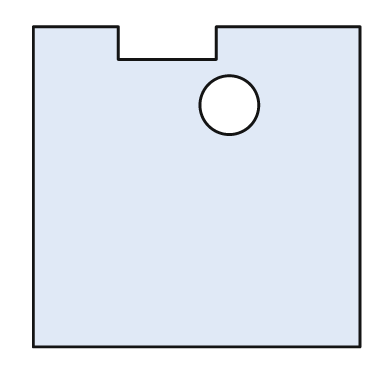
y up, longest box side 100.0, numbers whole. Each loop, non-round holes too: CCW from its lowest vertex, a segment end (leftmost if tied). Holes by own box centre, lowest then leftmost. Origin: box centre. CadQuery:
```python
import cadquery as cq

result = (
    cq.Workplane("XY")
    .moveTo(-50.0, -49.0)
    .lineTo(50.0, -49.0)
    .lineTo(50.0, 49.0)
    .lineTo(6.0, 49.0)
    .lineTo(6.0, 39.0)
    .lineTo(-24.0, 39.0)
    .lineTo(-24.0, 49.0)
    .lineTo(-50.0, 49.0)
    .close()
    .moveTo(10.0, 25.0)
    .circle(9.0)
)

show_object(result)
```